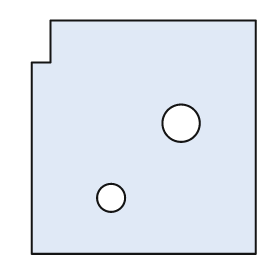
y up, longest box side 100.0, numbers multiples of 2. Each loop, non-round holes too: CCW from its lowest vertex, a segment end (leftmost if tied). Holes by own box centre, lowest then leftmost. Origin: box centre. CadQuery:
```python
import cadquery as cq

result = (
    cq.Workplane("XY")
    .moveTo(-48.0, -50.0)
    .lineTo(48.0, -50.0)
    .lineTo(48.0, 50.0)
    .lineTo(-40.0, 50.0)
    .lineTo(-40.0, 32.0)
    .lineTo(-48.0, 32.0)
    .close()
    .moveTo(-14.0, -26.0)
    .circle(6.0)
    .moveTo(16.0, 6.0)
    .circle(8.0)
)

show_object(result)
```